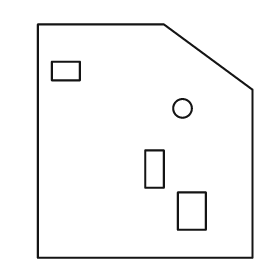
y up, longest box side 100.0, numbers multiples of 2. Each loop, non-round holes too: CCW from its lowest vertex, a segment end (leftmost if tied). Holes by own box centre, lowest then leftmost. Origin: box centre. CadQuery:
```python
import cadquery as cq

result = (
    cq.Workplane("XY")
    .moveTo(-46.0, -50.0)
    .lineTo(46.0, -50.0)
    .lineTo(46.0, 22.0)
    .lineTo(8.0, 50.0)
    .lineTo(-46.0, 50.0)
    .close()
    .moveTo(14.0, -38.0)
    .lineTo(26.0, -38.0)
    .lineTo(26.0, -22.0)
    .lineTo(14.0, -22.0)
    .close()
    .moveTo(0.0, -20.0)
    .lineTo(8.0, -20.0)
    .lineTo(8.0, -4.0)
    .lineTo(0.0, -4.0)
    .close()
    .moveTo(16.0, 14.0)
    .circle(4.0)
    .moveTo(-40.0, 26.0)
    .lineTo(-28.0, 26.0)
    .lineTo(-28.0, 34.0)
    .lineTo(-40.0, 34.0)
    .close()
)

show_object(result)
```